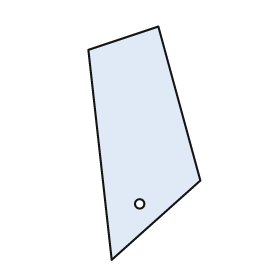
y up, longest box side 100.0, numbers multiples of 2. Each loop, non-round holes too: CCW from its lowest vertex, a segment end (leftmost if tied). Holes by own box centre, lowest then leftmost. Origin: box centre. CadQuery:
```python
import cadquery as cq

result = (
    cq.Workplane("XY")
    .moveTo(-14.0, -50.0)
    .lineTo(24.0, -16.0)
    .lineTo(6.0, 50.0)
    .lineTo(-24.0, 40.0)
    .close()
    .moveTo(-2.0, -26.0)
    .circle(2.0)
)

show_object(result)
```